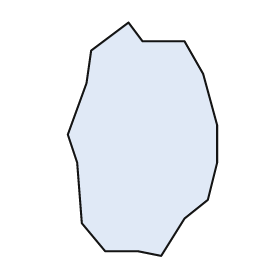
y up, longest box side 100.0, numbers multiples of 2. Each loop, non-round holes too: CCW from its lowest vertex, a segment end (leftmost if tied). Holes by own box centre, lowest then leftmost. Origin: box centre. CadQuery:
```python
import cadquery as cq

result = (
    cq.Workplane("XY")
    .moveTo(8.0, -50.0)
    .lineTo(18.0, -34.0)
    .lineTo(28.0, -26.0)
    .lineTo(32.0, -10.0)
    .lineTo(32.0, 6.0)
    .lineTo(26.0, 28.0)
    .lineTo(18.0, 42.0)
    .lineTo(0.0, 42.0)
    .lineTo(-6.0, 50.0)
    .lineTo(-22.0, 38.0)
    .lineTo(-24.0, 24.0)
    .lineTo(-32.0, 2.0)
    .lineTo(-28.0, -10.0)
    .lineTo(-26.0, -36.0)
    .lineTo(-16.0, -48.0)
    .lineTo(-2.0, -48.0)
    .close()
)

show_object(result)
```